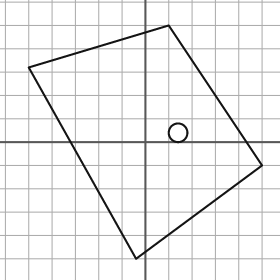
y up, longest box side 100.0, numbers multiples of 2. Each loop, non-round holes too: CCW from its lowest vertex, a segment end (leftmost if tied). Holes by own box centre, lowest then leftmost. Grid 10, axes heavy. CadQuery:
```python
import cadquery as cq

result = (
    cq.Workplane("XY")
    .moveTo(-4.0, -50.0)
    .lineTo(50.0, -10.0)
    .lineTo(10.0, 50.0)
    .lineTo(-50.0, 32.0)
    .close()
    .moveTo(14.0, 4.0)
    .circle(4.0)
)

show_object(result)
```